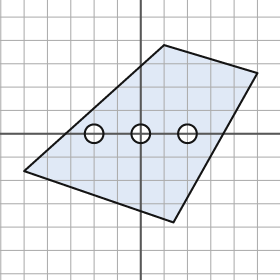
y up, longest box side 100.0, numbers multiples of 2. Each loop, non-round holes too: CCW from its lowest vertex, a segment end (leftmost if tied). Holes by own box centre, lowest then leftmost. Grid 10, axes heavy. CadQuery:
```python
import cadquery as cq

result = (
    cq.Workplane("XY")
    .moveTo(14.0, -38.0)
    .lineTo(50.0, 26.0)
    .lineTo(10.0, 38.0)
    .lineTo(-50.0, -16.0)
    .close()
    .moveTo(-20.0, 0.0)
    .circle(4.0)
    .moveTo(0.0, 0.0)
    .circle(4.0)
    .moveTo(20.0, 0.0)
    .circle(4.0)
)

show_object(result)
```